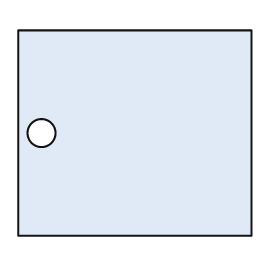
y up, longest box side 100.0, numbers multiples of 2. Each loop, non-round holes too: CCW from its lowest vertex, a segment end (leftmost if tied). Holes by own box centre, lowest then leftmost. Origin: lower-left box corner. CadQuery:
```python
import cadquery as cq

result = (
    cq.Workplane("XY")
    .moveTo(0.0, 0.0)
    .lineTo(100.0, 0.0)
    .lineTo(100.0, 88.0)
    .lineTo(0.0, 88.0)
    .close()
    .moveTo(10.0, 44.0)
    .circle(6.0)
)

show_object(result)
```